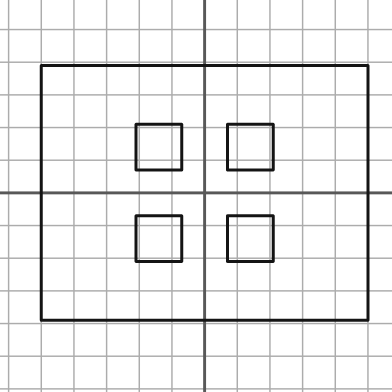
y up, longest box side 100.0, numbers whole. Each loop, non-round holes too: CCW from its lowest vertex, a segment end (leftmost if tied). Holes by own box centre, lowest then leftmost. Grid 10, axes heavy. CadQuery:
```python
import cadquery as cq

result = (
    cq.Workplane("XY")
    .moveTo(-50.0, -39.0)
    .lineTo(50.0, -39.0)
    .lineTo(50.0, 39.0)
    .lineTo(-50.0, 39.0)
    .close()
    .moveTo(-21.0, -21.0)
    .lineTo(-7.0, -21.0)
    .lineTo(-7.0, -7.0)
    .lineTo(-21.0, -7.0)
    .close()
    .moveTo(7.0, -21.0)
    .lineTo(21.0, -21.0)
    .lineTo(21.0, -7.0)
    .lineTo(7.0, -7.0)
    .close()
    .moveTo(-21.0, 7.0)
    .lineTo(-7.0, 7.0)
    .lineTo(-7.0, 21.0)
    .lineTo(-21.0, 21.0)
    .close()
    .moveTo(7.0, 7.0)
    .lineTo(21.0, 7.0)
    .lineTo(21.0, 21.0)
    .lineTo(7.0, 21.0)
    .close()
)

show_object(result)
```